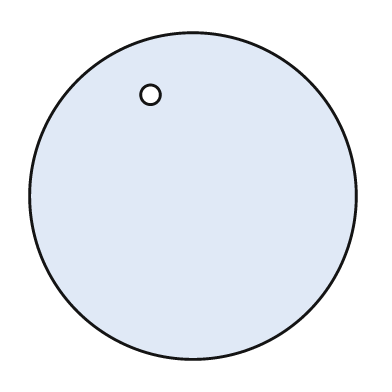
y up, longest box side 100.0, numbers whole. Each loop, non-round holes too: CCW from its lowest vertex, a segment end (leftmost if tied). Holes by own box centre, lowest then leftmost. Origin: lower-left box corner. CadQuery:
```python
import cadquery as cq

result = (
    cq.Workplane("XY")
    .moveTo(50.0, 50.0)
    .circle(50.0)
    .moveTo(37.0, 81.0)
    .circle(3.0)
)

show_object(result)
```